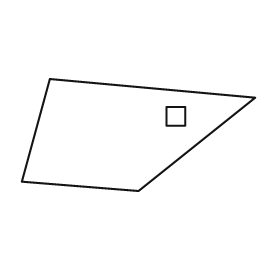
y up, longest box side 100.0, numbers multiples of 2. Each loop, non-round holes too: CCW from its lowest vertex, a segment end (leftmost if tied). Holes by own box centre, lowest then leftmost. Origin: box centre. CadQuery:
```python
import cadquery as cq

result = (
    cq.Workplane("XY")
    .moveTo(0.0, -24.0)
    .lineTo(50.0, 16.0)
    .lineTo(-38.0, 24.0)
    .lineTo(-50.0, -20.0)
    .close()
    .moveTo(12.0, 4.0)
    .lineTo(20.0, 4.0)
    .lineTo(20.0, 12.0)
    .lineTo(12.0, 12.0)
    .close()
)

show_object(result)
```